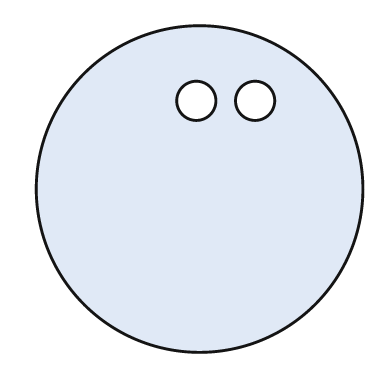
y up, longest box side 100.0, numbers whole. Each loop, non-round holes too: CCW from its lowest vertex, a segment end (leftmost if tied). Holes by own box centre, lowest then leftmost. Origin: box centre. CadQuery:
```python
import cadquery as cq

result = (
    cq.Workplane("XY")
    .moveTo(0.0, 0.0)
    .circle(50.0)
    .moveTo(-1.0, 27.0)
    .circle(6.0)
    .moveTo(17.0, 27.0)
    .circle(6.0)
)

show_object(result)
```